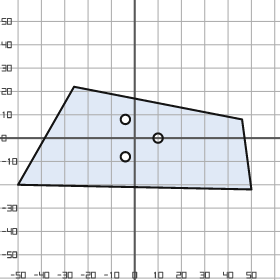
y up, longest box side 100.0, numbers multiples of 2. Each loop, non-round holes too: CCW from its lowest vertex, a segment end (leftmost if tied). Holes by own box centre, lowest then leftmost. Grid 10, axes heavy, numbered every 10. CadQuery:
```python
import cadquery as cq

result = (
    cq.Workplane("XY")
    .moveTo(50.0, -22.0)
    .lineTo(46.0, 8.0)
    .lineTo(-26.0, 22.0)
    .lineTo(-50.0, -20.0)
    .close()
    .moveTo(-4.0, -8.0)
    .circle(2.0)
    .moveTo(10.0, 0.0)
    .circle(2.0)
    .moveTo(-4.0, 8.0)
    .circle(2.0)
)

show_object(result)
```